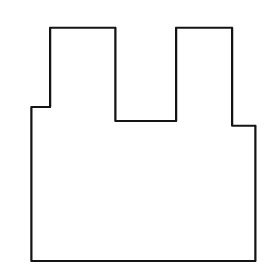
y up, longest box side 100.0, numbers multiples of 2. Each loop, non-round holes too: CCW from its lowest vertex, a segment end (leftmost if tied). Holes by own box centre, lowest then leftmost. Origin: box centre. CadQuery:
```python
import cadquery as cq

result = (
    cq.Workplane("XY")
    .moveTo(-48.0, -50.0)
    .lineTo(48.0, -50.0)
    .lineTo(48.0, 8.0)
    .lineTo(38.0, 8.0)
    .lineTo(38.0, 50.0)
    .lineTo(14.0, 50.0)
    .lineTo(14.0, 10.0)
    .lineTo(-12.0, 10.0)
    .lineTo(-12.0, 50.0)
    .lineTo(-40.0, 50.0)
    .lineTo(-40.0, 16.0)
    .lineTo(-48.0, 16.0)
    .close()
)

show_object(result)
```